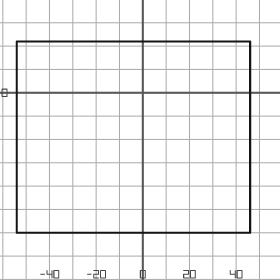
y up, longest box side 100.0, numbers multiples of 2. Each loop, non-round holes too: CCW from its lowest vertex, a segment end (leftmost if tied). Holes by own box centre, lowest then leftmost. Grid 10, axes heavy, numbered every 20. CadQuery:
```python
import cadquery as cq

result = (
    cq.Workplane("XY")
    .moveTo(-54.0, -60.0)
    .lineTo(46.0, -60.0)
    .lineTo(46.0, 22.0)
    .lineTo(-54.0, 22.0)
    .close()
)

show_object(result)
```